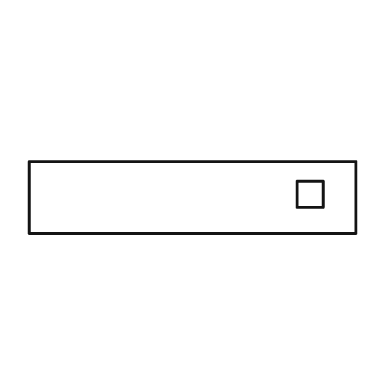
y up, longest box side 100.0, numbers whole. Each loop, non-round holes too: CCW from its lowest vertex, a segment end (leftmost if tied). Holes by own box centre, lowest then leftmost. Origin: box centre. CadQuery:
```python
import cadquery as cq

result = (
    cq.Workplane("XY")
    .moveTo(-50.0, -11.0)
    .lineTo(50.0, -11.0)
    .lineTo(50.0, 11.0)
    .lineTo(-50.0, 11.0)
    .close()
    .moveTo(32.0, -3.0)
    .lineTo(40.0, -3.0)
    .lineTo(40.0, 5.0)
    .lineTo(32.0, 5.0)
    .close()
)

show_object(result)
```